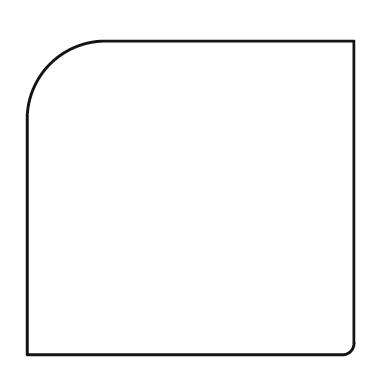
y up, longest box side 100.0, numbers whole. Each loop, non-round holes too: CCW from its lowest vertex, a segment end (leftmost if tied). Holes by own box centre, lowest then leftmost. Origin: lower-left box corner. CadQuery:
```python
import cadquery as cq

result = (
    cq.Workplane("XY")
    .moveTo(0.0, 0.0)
    .lineTo(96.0, 0.0)
    .threePointArc((99.0, 1.0), (100.0, 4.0))
    .lineTo(100.0, 96.0)
    .lineTo(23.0, 96.0)
    .threePointArc((7.0, 89.0), (0.0, 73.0))
    .close()
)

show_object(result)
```